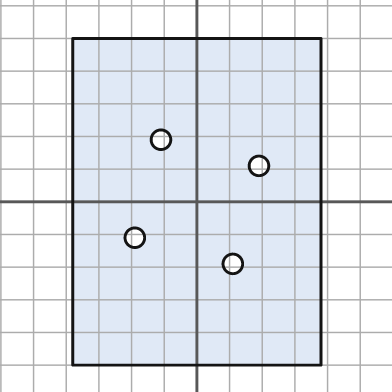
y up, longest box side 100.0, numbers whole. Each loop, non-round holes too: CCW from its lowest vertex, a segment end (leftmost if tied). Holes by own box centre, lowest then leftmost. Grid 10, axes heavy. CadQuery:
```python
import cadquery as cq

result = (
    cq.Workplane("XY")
    .moveTo(-38.0, -50.0)
    .lineTo(38.0, -50.0)
    .lineTo(38.0, 50.0)
    .lineTo(-38.0, 50.0)
    .close()
    .moveTo(11.0, -19.0)
    .circle(3.0)
    .moveTo(-19.0, -11.0)
    .circle(3.0)
    .moveTo(19.0, 11.0)
    .circle(3.0)
    .moveTo(-11.0, 19.0)
    .circle(3.0)
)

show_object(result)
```